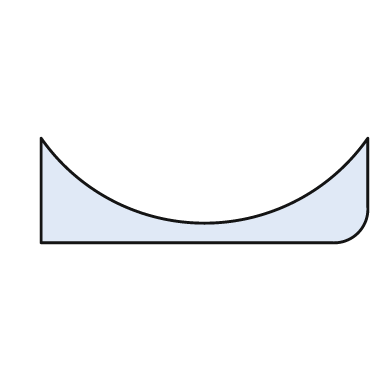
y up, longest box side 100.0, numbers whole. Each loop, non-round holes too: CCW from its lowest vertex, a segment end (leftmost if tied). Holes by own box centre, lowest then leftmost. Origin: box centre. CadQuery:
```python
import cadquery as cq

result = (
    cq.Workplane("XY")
    .moveTo(-50.0, -16.0)
    .lineTo(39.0, -16.0)
    .threePointArc((47.0, -13.0), (50.0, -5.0))
    .lineTo(50.0, 16.0)
    .threePointArc((0.0, -10.0), (-50.0, 16.0))
    .close()
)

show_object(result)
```